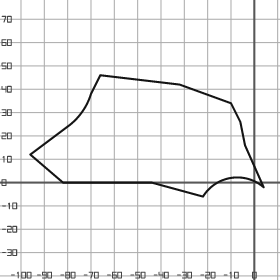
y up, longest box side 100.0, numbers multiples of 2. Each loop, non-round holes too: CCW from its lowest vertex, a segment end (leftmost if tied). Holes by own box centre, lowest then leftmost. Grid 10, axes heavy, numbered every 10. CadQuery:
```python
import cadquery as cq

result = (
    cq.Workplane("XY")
    .moveTo(-22.0, -6.0)
    .threePointArc((-10.0, 2.0), (4.0, -2.0))
    .lineTo(-4.0, 16.0)
    .lineTo(-6.0, 26.0)
    .lineTo(-10.0, 34.0)
    .lineTo(-32.0, 42.0)
    .lineTo(-66.0, 46.0)
    .lineTo(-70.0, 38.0)
    .threePointArc((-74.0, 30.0), (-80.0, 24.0))
    .lineTo(-96.0, 12.0)
    .lineTo(-82.0, 0.0)
    .lineTo(-44.0, 0.0)
    .close()
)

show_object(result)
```